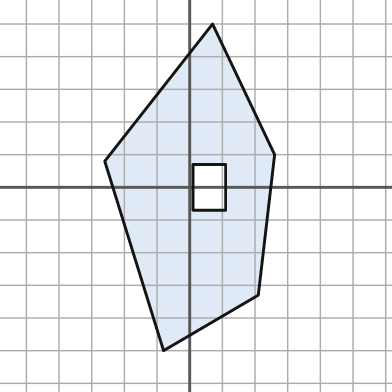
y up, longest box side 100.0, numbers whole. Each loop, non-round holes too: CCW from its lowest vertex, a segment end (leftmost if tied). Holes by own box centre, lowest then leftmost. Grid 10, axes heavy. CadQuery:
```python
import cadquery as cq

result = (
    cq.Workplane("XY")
    .moveTo(-8.0, -50.0)
    .lineTo(21.0, -33.0)
    .lineTo(26.0, 10.0)
    .lineTo(7.0, 50.0)
    .lineTo(-26.0, 8.0)
    .close()
    .moveTo(1.0, -7.0)
    .lineTo(11.0, -7.0)
    .lineTo(11.0, 7.0)
    .lineTo(1.0, 7.0)
    .close()
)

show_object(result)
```